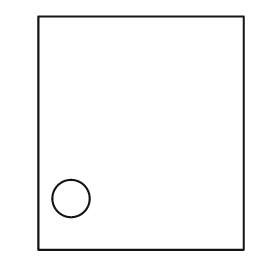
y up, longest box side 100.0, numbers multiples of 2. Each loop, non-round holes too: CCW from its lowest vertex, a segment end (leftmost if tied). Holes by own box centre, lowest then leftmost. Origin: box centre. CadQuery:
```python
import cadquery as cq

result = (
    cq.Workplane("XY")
    .moveTo(-44.0, -50.0)
    .lineTo(44.0, -50.0)
    .lineTo(44.0, 50.0)
    .lineTo(-44.0, 50.0)
    .close()
    .moveTo(-30.0, -28.0)
    .circle(8.0)
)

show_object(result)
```